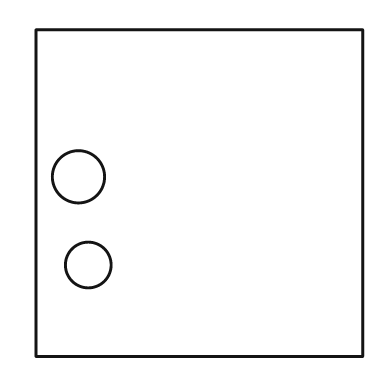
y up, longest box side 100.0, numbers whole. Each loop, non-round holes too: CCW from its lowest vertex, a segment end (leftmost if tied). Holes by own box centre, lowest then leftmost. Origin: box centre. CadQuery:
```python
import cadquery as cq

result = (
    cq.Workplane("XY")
    .moveTo(-50.0, -50.0)
    .lineTo(50.0, -50.0)
    .lineTo(50.0, 50.0)
    .lineTo(-50.0, 50.0)
    .close()
    .moveTo(-34.0, -22.0)
    .circle(7.0)
    .moveTo(-37.0, 5.0)
    .circle(8.0)
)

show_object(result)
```